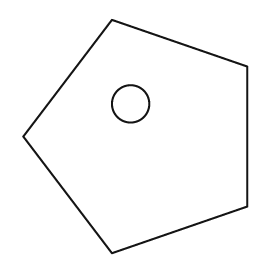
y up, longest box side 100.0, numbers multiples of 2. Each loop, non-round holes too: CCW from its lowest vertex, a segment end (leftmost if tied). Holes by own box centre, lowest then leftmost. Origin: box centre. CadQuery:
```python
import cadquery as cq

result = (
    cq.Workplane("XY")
    .moveTo(-10.0, -50.0)
    .lineTo(48.0, -30.0)
    .lineTo(48.0, 30.0)
    .lineTo(-10.0, 50.0)
    .lineTo(-48.0, 0.0)
    .close()
    .moveTo(-2.0, 14.0)
    .circle(8.0)
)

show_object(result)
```